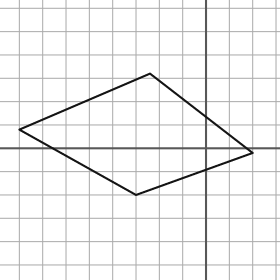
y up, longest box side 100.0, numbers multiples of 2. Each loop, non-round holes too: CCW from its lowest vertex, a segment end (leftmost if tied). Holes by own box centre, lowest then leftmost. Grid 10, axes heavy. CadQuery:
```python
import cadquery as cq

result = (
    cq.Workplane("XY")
    .moveTo(-30.0, -20.0)
    .lineTo(20.0, -2.0)
    .lineTo(-24.0, 32.0)
    .lineTo(-80.0, 8.0)
    .close()
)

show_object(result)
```